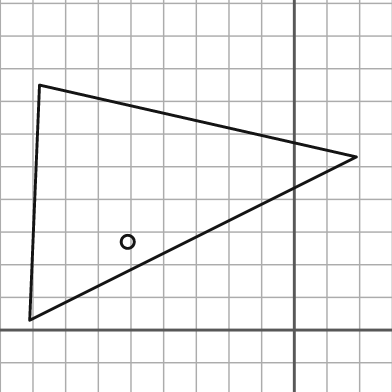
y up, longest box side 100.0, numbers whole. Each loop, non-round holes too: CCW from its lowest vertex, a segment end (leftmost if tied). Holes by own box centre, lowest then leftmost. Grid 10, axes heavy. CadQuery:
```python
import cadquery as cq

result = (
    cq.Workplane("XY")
    .moveTo(-81.0, 3.0)
    .lineTo(19.0, 53.0)
    .lineTo(-78.0, 75.0)
    .close()
    .moveTo(-51.0, 27.0)
    .circle(2.0)
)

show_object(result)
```